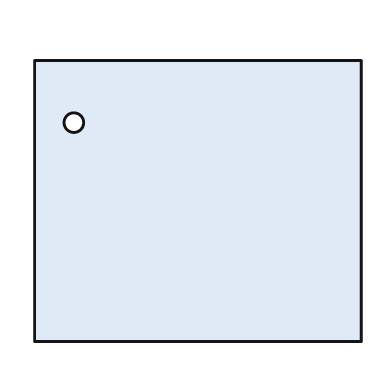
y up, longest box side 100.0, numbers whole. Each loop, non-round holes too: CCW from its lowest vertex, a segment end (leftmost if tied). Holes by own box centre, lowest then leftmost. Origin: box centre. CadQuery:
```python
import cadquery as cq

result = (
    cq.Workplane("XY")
    .moveTo(-50.0, -43.0)
    .lineTo(50.0, -43.0)
    .lineTo(50.0, 43.0)
    .lineTo(-50.0, 43.0)
    .close()
    .moveTo(-38.0, 24.0)
    .circle(3.0)
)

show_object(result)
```